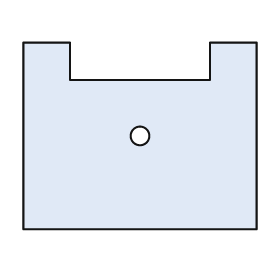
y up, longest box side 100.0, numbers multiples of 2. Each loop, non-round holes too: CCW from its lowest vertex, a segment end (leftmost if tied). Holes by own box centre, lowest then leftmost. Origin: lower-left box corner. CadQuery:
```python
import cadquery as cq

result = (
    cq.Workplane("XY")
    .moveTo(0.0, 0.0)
    .lineTo(100.0, 0.0)
    .lineTo(100.0, 80.0)
    .lineTo(80.0, 80.0)
    .lineTo(80.0, 64.0)
    .lineTo(20.0, 64.0)
    .lineTo(20.0, 80.0)
    .lineTo(0.0, 80.0)
    .close()
    .moveTo(50.0, 40.0)
    .circle(4.0)
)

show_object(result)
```